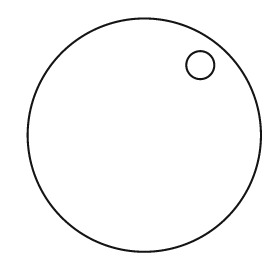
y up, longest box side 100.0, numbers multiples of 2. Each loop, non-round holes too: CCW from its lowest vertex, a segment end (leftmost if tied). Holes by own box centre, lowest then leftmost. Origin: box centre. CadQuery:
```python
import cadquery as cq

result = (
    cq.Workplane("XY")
    .moveTo(0.0, 0.0)
    .circle(50.0)
    .moveTo(24.0, 30.0)
    .circle(6.0)
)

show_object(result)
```